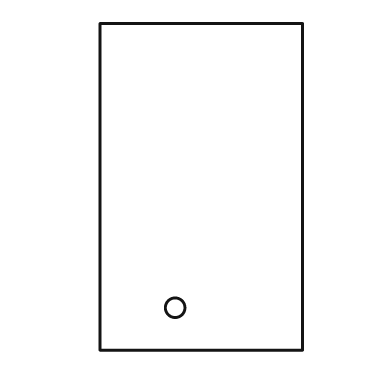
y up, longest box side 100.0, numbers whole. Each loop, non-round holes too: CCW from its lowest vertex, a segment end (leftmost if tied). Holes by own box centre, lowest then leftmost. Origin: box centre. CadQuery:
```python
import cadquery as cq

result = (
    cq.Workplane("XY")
    .moveTo(-31.0, -50.0)
    .lineTo(31.0, -50.0)
    .lineTo(31.0, 50.0)
    .lineTo(-31.0, 50.0)
    .close()
    .moveTo(-8.0, -37.0)
    .circle(3.0)
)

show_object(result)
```